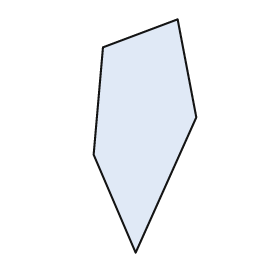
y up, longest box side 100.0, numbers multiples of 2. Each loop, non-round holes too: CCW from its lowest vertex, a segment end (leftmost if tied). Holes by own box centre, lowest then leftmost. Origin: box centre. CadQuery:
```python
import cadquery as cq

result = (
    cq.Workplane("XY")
    .moveTo(-4.0, -50.0)
    .lineTo(22.0, 8.0)
    .lineTo(14.0, 50.0)
    .lineTo(-18.0, 38.0)
    .lineTo(-22.0, -8.0)
    .close()
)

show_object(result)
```